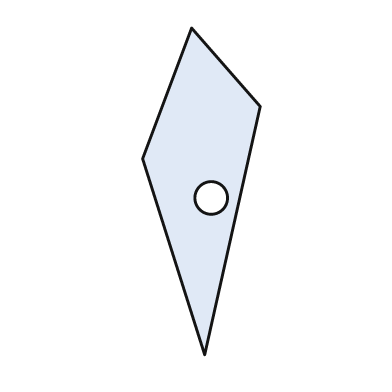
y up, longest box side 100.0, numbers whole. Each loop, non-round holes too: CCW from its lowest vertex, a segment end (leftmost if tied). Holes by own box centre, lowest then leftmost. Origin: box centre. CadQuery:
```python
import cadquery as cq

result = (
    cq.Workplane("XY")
    .moveTo(1.0, -50.0)
    .lineTo(18.0, 26.0)
    .lineTo(-3.0, 50.0)
    .lineTo(-18.0, 10.0)
    .close()
    .moveTo(3.0, -2.0)
    .circle(5.0)
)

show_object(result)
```